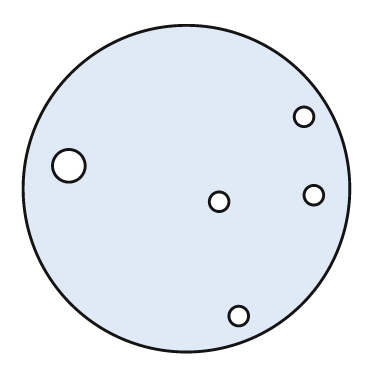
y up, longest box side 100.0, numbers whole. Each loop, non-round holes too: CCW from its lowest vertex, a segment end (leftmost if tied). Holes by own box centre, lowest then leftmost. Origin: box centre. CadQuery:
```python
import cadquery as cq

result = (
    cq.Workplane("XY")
    .moveTo(0.0, 0.0)
    .circle(50.0)
    .moveTo(16.0, -39.0)
    .circle(3.0)
    .moveTo(10.0, -4.0)
    .circle(3.0)
    .moveTo(39.0, -2.0)
    .circle(3.0)
    .moveTo(-36.0, 7.0)
    .circle(5.0)
    .moveTo(36.0, 22.0)
    .circle(3.0)
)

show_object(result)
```